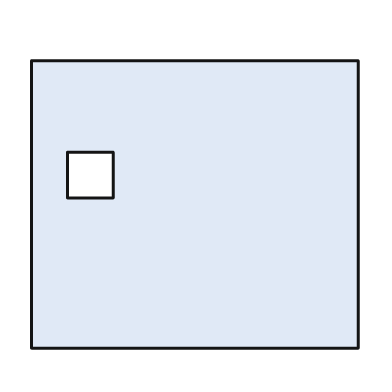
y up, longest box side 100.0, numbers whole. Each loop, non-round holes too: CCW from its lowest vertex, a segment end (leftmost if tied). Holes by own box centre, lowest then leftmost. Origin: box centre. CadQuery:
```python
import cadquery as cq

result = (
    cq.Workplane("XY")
    .moveTo(-50.0, -44.0)
    .lineTo(50.0, -44.0)
    .lineTo(50.0, 44.0)
    .lineTo(-50.0, 44.0)
    .close()
    .moveTo(-39.0, 2.0)
    .lineTo(-25.0, 2.0)
    .lineTo(-25.0, 16.0)
    .lineTo(-39.0, 16.0)
    .close()
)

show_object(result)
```